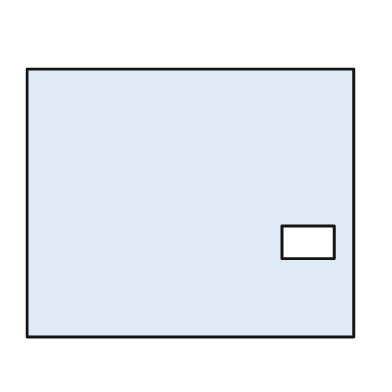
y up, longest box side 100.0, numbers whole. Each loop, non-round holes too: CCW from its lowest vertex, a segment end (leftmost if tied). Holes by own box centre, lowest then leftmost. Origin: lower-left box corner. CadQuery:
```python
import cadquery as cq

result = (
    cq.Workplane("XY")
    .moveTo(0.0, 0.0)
    .lineTo(100.0, 0.0)
    .lineTo(100.0, 82.0)
    .lineTo(0.0, 82.0)
    .close()
    .moveTo(78.0, 24.0)
    .lineTo(94.0, 24.0)
    .lineTo(94.0, 34.0)
    .lineTo(78.0, 34.0)
    .close()
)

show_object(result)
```